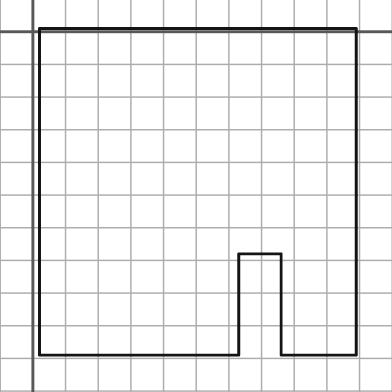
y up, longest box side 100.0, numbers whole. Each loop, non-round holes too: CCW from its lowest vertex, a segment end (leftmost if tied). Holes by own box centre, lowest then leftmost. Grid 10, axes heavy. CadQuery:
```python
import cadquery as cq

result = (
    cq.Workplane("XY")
    .moveTo(2.0, -99.0)
    .lineTo(63.0, -99.0)
    .lineTo(63.0, -68.0)
    .lineTo(76.0, -68.0)
    .lineTo(76.0, -99.0)
    .lineTo(99.0, -99.0)
    .lineTo(99.0, 1.0)
    .lineTo(2.0, 1.0)
    .close()
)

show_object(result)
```